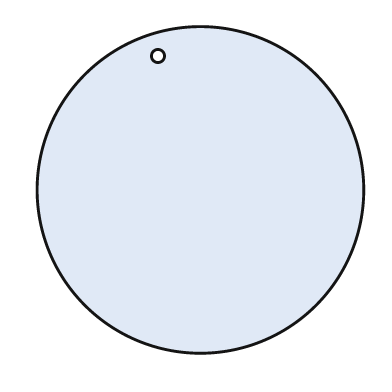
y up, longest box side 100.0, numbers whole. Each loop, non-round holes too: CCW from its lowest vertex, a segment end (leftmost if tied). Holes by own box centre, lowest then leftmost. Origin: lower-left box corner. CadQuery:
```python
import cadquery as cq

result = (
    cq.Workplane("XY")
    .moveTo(50.0, 50.0)
    .circle(50.0)
    .moveTo(37.0, 91.0)
    .circle(2.0)
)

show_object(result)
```